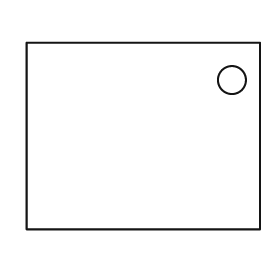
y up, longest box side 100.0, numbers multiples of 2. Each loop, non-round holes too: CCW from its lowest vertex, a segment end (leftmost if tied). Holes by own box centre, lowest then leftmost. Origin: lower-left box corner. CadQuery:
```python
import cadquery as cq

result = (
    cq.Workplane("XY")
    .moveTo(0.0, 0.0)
    .lineTo(100.0, 0.0)
    .lineTo(100.0, 80.0)
    .lineTo(0.0, 80.0)
    .close()
    .moveTo(88.0, 64.0)
    .circle(6.0)
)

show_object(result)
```